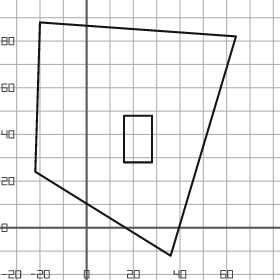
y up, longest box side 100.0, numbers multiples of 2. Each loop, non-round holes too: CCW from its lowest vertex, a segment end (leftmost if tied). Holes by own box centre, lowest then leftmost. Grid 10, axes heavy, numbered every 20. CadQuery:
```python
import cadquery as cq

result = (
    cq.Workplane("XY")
    .moveTo(36.0, -12.0)
    .lineTo(64.0, 82.0)
    .lineTo(-20.0, 88.0)
    .lineTo(-22.0, 24.0)
    .close()
    .moveTo(16.0, 28.0)
    .lineTo(28.0, 28.0)
    .lineTo(28.0, 48.0)
    .lineTo(16.0, 48.0)
    .close()
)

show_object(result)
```